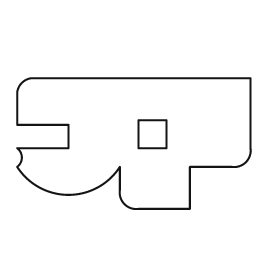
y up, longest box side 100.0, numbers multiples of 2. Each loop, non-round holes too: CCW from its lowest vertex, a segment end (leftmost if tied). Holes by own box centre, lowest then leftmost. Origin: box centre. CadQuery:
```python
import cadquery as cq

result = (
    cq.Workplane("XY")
    .moveTo(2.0, -28.0)
    .lineTo(24.0, -28.0)
    .lineTo(24.0, -10.0)
    .lineTo(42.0, -10.0)
    .threePointArc((48.0, -8.0), (50.0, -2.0))
    .lineTo(50.0, 28.0)
    .lineTo(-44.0, 28.0)
    .threePointArc((-48.0, 26.0), (-50.0, 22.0))
    .lineTo(-50.0, 8.0)
    .lineTo(-28.0, 8.0)
    .lineTo(-28.0, -2.0)
    .lineTo(-50.0, -2.0)
    .threePointArc((-48.0, -6.0), (-50.0, -10.0))
    .threePointArc((-28.0, -22.0), (-6.0, -10.0))
    .lineTo(-6.0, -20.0)
    .threePointArc((-4.0, -26.0), (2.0, -28.0))
    .close()
    .moveTo(2.0, -2.0)
    .lineTo(14.0, -2.0)
    .lineTo(14.0, 10.0)
    .lineTo(2.0, 10.0)
    .close()
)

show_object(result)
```